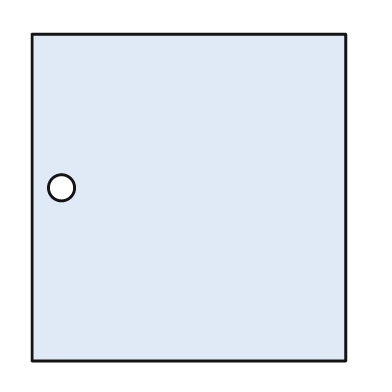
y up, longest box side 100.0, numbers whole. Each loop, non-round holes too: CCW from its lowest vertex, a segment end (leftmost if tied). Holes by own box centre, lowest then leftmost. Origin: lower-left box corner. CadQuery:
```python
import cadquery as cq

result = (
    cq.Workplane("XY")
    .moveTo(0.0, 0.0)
    .lineTo(96.0, 0.0)
    .lineTo(96.0, 100.0)
    .lineTo(0.0, 100.0)
    .close()
    .moveTo(9.0, 53.0)
    .circle(4.0)
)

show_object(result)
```